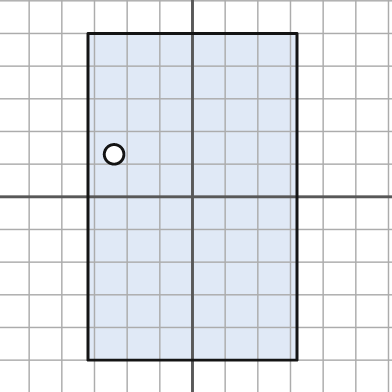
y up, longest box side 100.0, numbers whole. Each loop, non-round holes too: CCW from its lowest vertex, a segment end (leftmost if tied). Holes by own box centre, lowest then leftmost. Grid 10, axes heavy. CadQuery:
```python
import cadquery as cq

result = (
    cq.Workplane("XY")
    .moveTo(-32.0, -50.0)
    .lineTo(32.0, -50.0)
    .lineTo(32.0, 50.0)
    .lineTo(-32.0, 50.0)
    .close()
    .moveTo(-24.0, 13.0)
    .circle(3.0)
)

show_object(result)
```